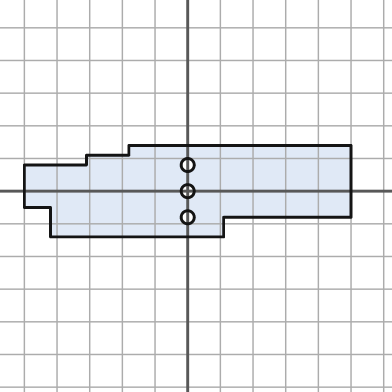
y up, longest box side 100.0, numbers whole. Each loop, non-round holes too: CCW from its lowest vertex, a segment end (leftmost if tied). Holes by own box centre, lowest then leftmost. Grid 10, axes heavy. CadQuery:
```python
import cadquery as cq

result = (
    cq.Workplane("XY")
    .moveTo(-42.0, -14.0)
    .lineTo(11.0, -14.0)
    .lineTo(11.0, -8.0)
    .lineTo(50.0, -8.0)
    .lineTo(50.0, 14.0)
    .lineTo(-18.0, 14.0)
    .lineTo(-18.0, 11.0)
    .lineTo(-31.0, 11.0)
    .lineTo(-31.0, 8.0)
    .lineTo(-50.0, 8.0)
    .lineTo(-50.0, -5.0)
    .lineTo(-42.0, -5.0)
    .close()
    .moveTo(0.0, -8.0)
    .circle(2.0)
    .moveTo(0.0, 0.0)
    .circle(2.0)
    .moveTo(0.0, 8.0)
    .circle(2.0)
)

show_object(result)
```